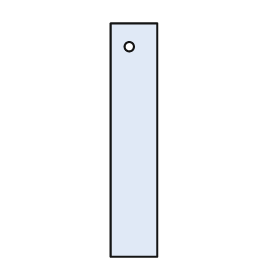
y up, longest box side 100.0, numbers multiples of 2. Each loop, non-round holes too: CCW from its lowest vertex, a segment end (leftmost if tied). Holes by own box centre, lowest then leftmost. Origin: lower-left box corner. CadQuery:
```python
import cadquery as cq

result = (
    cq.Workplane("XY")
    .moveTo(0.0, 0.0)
    .lineTo(20.0, 0.0)
    .lineTo(20.0, 100.0)
    .lineTo(0.0, 100.0)
    .close()
    .moveTo(8.0, 90.0)
    .circle(2.0)
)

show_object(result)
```